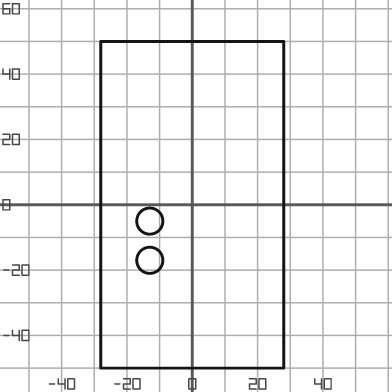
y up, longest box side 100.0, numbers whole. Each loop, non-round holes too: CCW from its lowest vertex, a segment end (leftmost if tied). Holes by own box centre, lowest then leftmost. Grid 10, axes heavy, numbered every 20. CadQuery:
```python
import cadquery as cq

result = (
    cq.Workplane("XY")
    .moveTo(-28.0, -50.0)
    .lineTo(28.0, -50.0)
    .lineTo(28.0, 50.0)
    .lineTo(-28.0, 50.0)
    .close()
    .moveTo(-13.0, -17.0)
    .circle(4.0)
    .moveTo(-13.0, -5.0)
    .circle(4.0)
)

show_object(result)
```